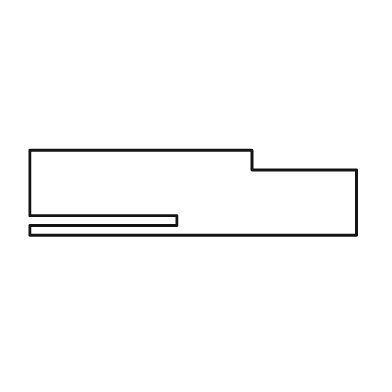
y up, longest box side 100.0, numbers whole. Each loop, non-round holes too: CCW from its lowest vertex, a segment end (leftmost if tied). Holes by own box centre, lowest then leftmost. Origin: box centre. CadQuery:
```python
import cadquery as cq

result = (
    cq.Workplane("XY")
    .moveTo(-50.0, -13.0)
    .lineTo(50.0, -13.0)
    .lineTo(50.0, 7.0)
    .lineTo(18.0, 7.0)
    .lineTo(18.0, 13.0)
    .lineTo(-50.0, 13.0)
    .lineTo(-50.0, -7.0)
    .lineTo(-5.0, -7.0)
    .lineTo(-5.0, -10.0)
    .lineTo(-50.0, -10.0)
    .close()
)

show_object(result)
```